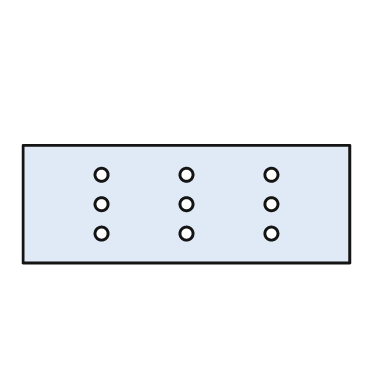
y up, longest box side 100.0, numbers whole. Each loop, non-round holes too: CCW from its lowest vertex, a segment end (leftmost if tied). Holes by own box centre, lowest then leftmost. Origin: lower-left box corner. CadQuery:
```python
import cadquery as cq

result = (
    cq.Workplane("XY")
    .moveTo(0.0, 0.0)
    .lineTo(100.0, 0.0)
    .lineTo(100.0, 36.0)
    .lineTo(0.0, 36.0)
    .close()
    .moveTo(24.0, 9.0)
    .circle(2.0)
    .moveTo(50.0, 9.0)
    .circle(2.0)
    .moveTo(76.0, 9.0)
    .circle(2.0)
    .moveTo(24.0, 18.0)
    .circle(2.0)
    .moveTo(50.0, 18.0)
    .circle(2.0)
    .moveTo(76.0, 18.0)
    .circle(2.0)
    .moveTo(24.0, 27.0)
    .circle(2.0)
    .moveTo(50.0, 27.0)
    .circle(2.0)
    .moveTo(76.0, 27.0)
    .circle(2.0)
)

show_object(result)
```